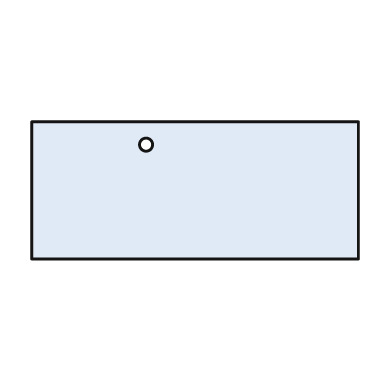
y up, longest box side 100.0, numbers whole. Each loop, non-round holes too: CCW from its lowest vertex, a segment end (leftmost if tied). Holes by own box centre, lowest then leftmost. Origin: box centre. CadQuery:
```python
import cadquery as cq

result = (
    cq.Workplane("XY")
    .moveTo(-50.0, -21.0)
    .lineTo(50.0, -21.0)
    .lineTo(50.0, 21.0)
    .lineTo(-50.0, 21.0)
    .close()
    .moveTo(-15.0, 14.0)
    .circle(2.0)
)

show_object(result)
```